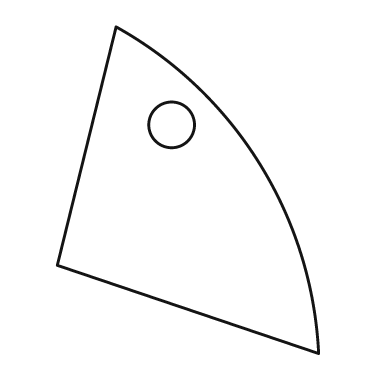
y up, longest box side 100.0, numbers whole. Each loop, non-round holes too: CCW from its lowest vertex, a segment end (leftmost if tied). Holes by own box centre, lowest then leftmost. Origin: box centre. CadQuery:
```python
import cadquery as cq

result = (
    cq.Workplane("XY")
    .moveTo(40.0, -50.0)
    .threePointArc((22.0, 8.0), (-22.0, 50.0))
    .lineTo(-40.0, -23.0)
    .close()
    .moveTo(-5.0, 20.0)
    .circle(7.0)
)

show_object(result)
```